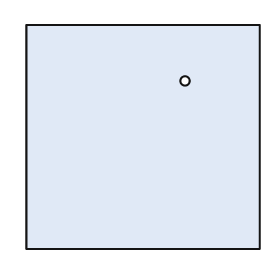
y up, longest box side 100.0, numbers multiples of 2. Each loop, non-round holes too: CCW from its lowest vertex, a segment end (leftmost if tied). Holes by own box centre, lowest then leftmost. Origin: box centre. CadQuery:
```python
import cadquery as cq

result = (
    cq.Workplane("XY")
    .moveTo(-50.0, -48.0)
    .lineTo(50.0, -48.0)
    .lineTo(50.0, 48.0)
    .lineTo(-50.0, 48.0)
    .close()
    .moveTo(18.0, 24.0)
    .circle(2.0)
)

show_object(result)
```